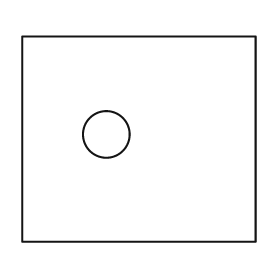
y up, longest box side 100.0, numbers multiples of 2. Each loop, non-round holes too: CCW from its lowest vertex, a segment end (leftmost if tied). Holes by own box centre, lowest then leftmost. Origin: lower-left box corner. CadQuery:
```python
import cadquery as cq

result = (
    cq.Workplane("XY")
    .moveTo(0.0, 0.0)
    .lineTo(100.0, 0.0)
    .lineTo(100.0, 88.0)
    .lineTo(0.0, 88.0)
    .close()
    .moveTo(36.0, 46.0)
    .circle(10.0)
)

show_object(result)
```